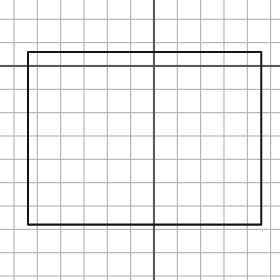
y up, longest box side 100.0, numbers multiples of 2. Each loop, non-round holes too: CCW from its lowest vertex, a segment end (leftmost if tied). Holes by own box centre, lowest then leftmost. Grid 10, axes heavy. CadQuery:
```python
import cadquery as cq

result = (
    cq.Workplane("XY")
    .moveTo(-54.0, -68.0)
    .lineTo(46.0, -68.0)
    .lineTo(46.0, 6.0)
    .lineTo(-54.0, 6.0)
    .close()
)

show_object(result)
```